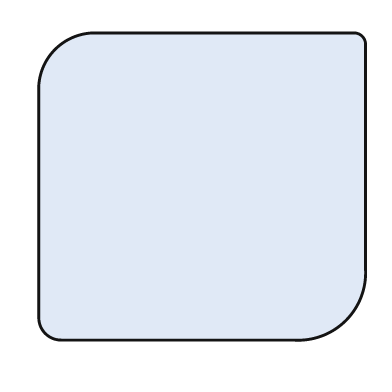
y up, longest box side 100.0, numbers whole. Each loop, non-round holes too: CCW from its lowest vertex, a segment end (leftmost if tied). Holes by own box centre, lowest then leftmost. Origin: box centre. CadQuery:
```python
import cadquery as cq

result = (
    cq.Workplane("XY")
    .moveTo(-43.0, -47.0)
    .lineTo(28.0, -47.0)
    .threePointArc((44.0, -41.0), (50.0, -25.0))
    .lineTo(50.0, 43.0)
    .threePointArc((49.0, 46.0), (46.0, 47.0))
    .lineTo(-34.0, 47.0)
    .threePointArc((-45.0, 42.0), (-50.0, 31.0))
    .lineTo(-50.0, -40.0)
    .threePointArc((-48.0, -45.0), (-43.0, -47.0))
    .close()
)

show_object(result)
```